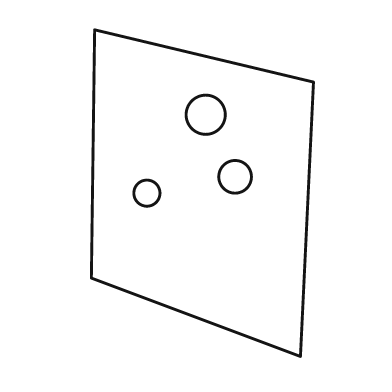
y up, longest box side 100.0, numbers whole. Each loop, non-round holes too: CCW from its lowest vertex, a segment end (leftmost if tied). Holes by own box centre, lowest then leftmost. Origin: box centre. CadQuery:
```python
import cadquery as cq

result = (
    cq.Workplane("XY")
    .moveTo(30.0, -50.0)
    .lineTo(34.0, 34.0)
    .lineTo(-33.0, 50.0)
    .lineTo(-34.0, -26.0)
    .close()
    .moveTo(-17.0, 0.0)
    .circle(4.0)
    .moveTo(10.0, 5.0)
    .circle(5.0)
    .moveTo(1.0, 24.0)
    .circle(6.0)
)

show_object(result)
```